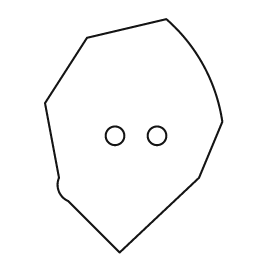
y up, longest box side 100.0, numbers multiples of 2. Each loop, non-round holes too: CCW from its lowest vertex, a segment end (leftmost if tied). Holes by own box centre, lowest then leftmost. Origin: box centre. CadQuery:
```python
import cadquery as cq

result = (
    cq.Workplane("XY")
    .moveTo(-6.0, -50.0)
    .lineTo(28.0, -18.0)
    .lineTo(38.0, 6.0)
    .threePointArc((30.0, 30.0), (14.0, 50.0))
    .lineTo(-20.0, 42.0)
    .lineTo(-38.0, 14.0)
    .lineTo(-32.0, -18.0)
    .threePointArc((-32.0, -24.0), (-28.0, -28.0))
    .close()
    .moveTo(-8.0, 0.0)
    .circle(4.0)
    .moveTo(10.0, 0.0)
    .circle(4.0)
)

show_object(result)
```